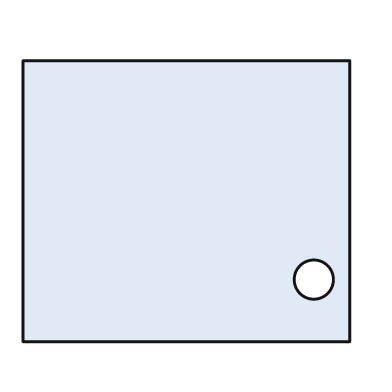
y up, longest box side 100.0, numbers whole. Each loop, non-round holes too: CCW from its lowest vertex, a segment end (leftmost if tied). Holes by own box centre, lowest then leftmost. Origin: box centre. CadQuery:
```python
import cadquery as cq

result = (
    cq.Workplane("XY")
    .moveTo(-50.0, -43.0)
    .lineTo(50.0, -43.0)
    .lineTo(50.0, 43.0)
    .lineTo(-50.0, 43.0)
    .close()
    .moveTo(39.0, -24.0)
    .circle(6.0)
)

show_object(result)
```